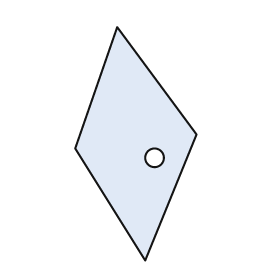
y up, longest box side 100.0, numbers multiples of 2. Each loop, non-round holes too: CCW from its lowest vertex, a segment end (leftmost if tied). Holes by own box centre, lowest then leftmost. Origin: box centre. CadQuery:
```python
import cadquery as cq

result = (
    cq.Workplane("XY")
    .moveTo(4.0, -50.0)
    .lineTo(26.0, 4.0)
    .lineTo(-8.0, 50.0)
    .lineTo(-26.0, -2.0)
    .close()
    .moveTo(8.0, -6.0)
    .circle(4.0)
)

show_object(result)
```